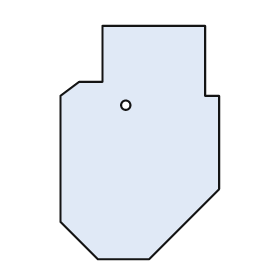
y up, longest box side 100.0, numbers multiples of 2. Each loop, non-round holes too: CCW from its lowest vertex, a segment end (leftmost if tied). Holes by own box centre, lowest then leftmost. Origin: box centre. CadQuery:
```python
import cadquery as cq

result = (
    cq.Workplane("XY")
    .moveTo(-18.0, -50.0)
    .lineTo(4.0, -50.0)
    .lineTo(34.0, -20.0)
    .lineTo(34.0, 20.0)
    .lineTo(28.0, 20.0)
    .lineTo(28.0, 50.0)
    .lineTo(-16.0, 50.0)
    .lineTo(-16.0, 26.0)
    .lineTo(-26.0, 26.0)
    .lineTo(-34.0, 20.0)
    .lineTo(-34.0, -34.0)
    .close()
    .moveTo(-6.0, 16.0)
    .circle(2.0)
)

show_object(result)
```